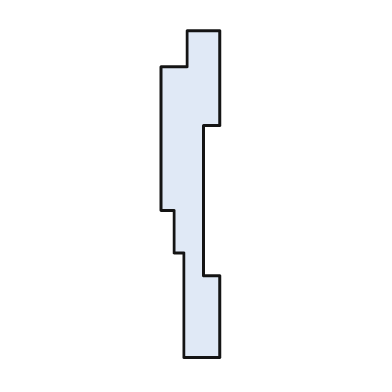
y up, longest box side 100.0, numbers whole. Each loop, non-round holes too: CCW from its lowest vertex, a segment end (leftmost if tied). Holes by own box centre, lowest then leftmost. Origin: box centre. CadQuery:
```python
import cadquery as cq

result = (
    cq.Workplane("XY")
    .moveTo(-2.0, -50.0)
    .lineTo(9.0, -50.0)
    .lineTo(9.0, -25.0)
    .lineTo(4.0, -25.0)
    .lineTo(4.0, 21.0)
    .lineTo(9.0, 21.0)
    .lineTo(9.0, 50.0)
    .lineTo(-1.0, 50.0)
    .lineTo(-1.0, 39.0)
    .lineTo(-9.0, 39.0)
    .lineTo(-9.0, -5.0)
    .lineTo(-5.0, -5.0)
    .lineTo(-5.0, -18.0)
    .lineTo(-2.0, -18.0)
    .close()
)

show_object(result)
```